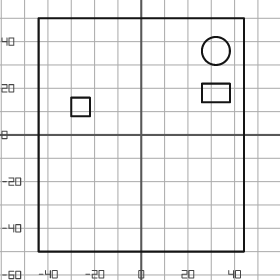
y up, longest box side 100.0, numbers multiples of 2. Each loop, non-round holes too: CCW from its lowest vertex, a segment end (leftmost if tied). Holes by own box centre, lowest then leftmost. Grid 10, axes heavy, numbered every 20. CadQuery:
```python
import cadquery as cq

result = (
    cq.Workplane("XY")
    .moveTo(-44.0, -50.0)
    .lineTo(44.0, -50.0)
    .lineTo(44.0, 50.0)
    .lineTo(-44.0, 50.0)
    .close()
    .moveTo(-30.0, 8.0)
    .lineTo(-22.0, 8.0)
    .lineTo(-22.0, 16.0)
    .lineTo(-30.0, 16.0)
    .close()
    .moveTo(26.0, 14.0)
    .lineTo(38.0, 14.0)
    .lineTo(38.0, 22.0)
    .lineTo(26.0, 22.0)
    .close()
    .moveTo(32.0, 36.0)
    .circle(6.0)
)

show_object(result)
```